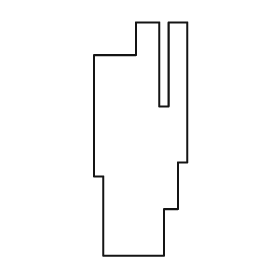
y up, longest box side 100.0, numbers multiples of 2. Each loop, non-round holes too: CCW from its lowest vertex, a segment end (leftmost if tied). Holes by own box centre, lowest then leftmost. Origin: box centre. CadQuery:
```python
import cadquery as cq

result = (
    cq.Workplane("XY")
    .moveTo(-16.0, -50.0)
    .lineTo(10.0, -50.0)
    .lineTo(10.0, -30.0)
    .lineTo(16.0, -30.0)
    .lineTo(16.0, -10.0)
    .lineTo(20.0, -10.0)
    .lineTo(20.0, 50.0)
    .lineTo(12.0, 50.0)
    .lineTo(12.0, 14.0)
    .lineTo(8.0, 14.0)
    .lineTo(8.0, 50.0)
    .lineTo(-2.0, 50.0)
    .lineTo(-2.0, 36.0)
    .lineTo(-20.0, 36.0)
    .lineTo(-20.0, -16.0)
    .lineTo(-16.0, -16.0)
    .close()
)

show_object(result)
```